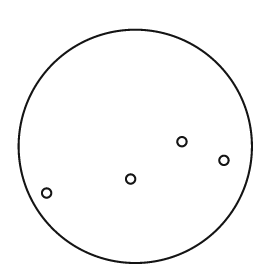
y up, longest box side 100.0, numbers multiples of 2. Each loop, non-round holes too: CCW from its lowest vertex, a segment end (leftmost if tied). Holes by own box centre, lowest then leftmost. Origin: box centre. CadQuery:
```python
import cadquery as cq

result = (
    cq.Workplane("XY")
    .moveTo(0.0, 0.0)
    .circle(50.0)
    .moveTo(-38.0, -20.0)
    .circle(2.0)
    .moveTo(-2.0, -14.0)
    .circle(2.0)
    .moveTo(38.0, -6.0)
    .circle(2.0)
    .moveTo(20.0, 2.0)
    .circle(2.0)
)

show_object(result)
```